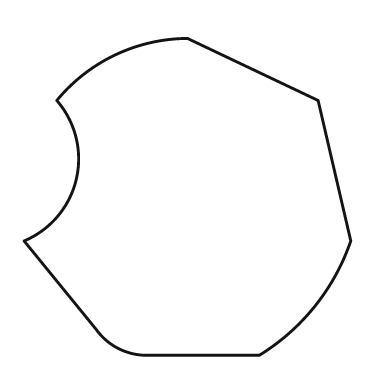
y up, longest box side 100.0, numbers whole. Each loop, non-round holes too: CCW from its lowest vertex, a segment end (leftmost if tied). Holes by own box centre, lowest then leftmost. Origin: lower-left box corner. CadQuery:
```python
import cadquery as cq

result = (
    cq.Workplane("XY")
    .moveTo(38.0, 0.0)
    .lineTo(72.0, 0.0)
    .threePointArc((89.0, 15.0), (100.0, 35.0))
    .lineTo(90.0, 78.0)
    .lineTo(50.0, 97.0)
    .threePointArc((28.0, 92.0), (10.0, 78.0))
    .threePointArc((16.0, 54.0), (0.0, 35.0))
    .lineTo(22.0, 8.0)
    .threePointArc((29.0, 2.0), (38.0, 0.0))
    .close()
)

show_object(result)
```